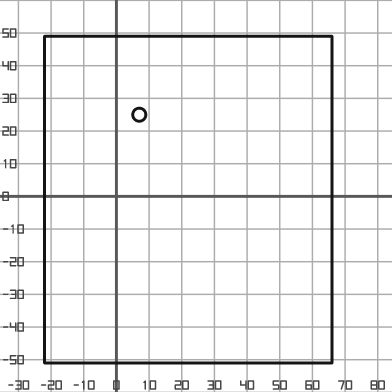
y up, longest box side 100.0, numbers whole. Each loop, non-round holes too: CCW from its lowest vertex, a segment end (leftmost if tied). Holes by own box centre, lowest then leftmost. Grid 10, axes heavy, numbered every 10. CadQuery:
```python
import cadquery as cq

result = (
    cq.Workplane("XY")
    .moveTo(-22.0, -51.0)
    .lineTo(66.0, -51.0)
    .lineTo(66.0, 49.0)
    .lineTo(-22.0, 49.0)
    .close()
    .moveTo(7.0, 25.0)
    .circle(2.0)
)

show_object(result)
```